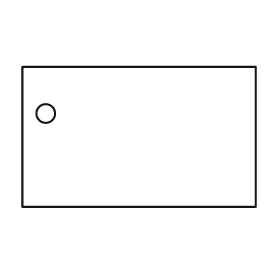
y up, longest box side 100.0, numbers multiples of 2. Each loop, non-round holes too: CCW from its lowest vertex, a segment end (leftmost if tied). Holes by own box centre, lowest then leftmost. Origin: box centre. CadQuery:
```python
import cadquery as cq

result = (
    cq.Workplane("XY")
    .moveTo(-50.0, -30.0)
    .lineTo(50.0, -30.0)
    .lineTo(50.0, 30.0)
    .lineTo(-50.0, 30.0)
    .close()
    .moveTo(-40.0, 10.0)
    .circle(4.0)
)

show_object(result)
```